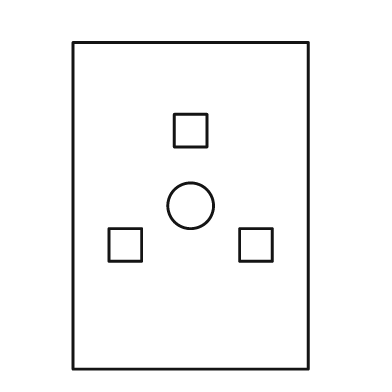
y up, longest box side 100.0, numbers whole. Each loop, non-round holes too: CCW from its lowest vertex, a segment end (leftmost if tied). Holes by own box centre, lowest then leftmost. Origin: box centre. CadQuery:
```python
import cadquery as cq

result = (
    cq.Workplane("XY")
    .moveTo(-36.0, -50.0)
    .lineTo(36.0, -50.0)
    .lineTo(36.0, 50.0)
    .lineTo(-36.0, 50.0)
    .close()
    .moveTo(-25.0, -17.0)
    .lineTo(-15.0, -17.0)
    .lineTo(-15.0, -7.0)
    .lineTo(-25.0, -7.0)
    .close()
    .moveTo(15.0, -17.0)
    .lineTo(25.0, -17.0)
    .lineTo(25.0, -7.0)
    .lineTo(15.0, -7.0)
    .close()
    .moveTo(0.0, 0.0)
    .circle(7.0)
    .moveTo(-5.0, 18.0)
    .lineTo(5.0, 18.0)
    .lineTo(5.0, 28.0)
    .lineTo(-5.0, 28.0)
    .close()
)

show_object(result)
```